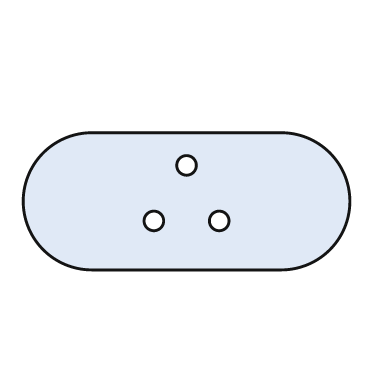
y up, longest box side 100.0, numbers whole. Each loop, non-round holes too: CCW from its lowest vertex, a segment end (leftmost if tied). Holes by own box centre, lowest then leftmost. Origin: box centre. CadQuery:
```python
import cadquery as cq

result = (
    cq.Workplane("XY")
    .moveTo(-29.0, -21.0)
    .lineTo(29.0, -21.0)
    .threePointArc((50.0, 0.0), (29.0, 21.0))
    .lineTo(-29.0, 21.0)
    .threePointArc((-50.0, 0.0), (-29.0, -21.0))
    .close()
    .moveTo(-10.0, -6.0)
    .circle(3.0)
    .moveTo(10.0, -6.0)
    .circle(3.0)
    .moveTo(0.0, 11.0)
    .circle(3.0)
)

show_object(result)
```